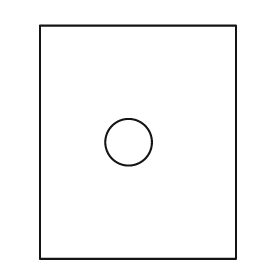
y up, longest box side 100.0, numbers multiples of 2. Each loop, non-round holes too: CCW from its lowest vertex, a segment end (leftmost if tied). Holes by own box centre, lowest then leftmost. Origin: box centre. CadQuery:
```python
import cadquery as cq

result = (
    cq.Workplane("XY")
    .moveTo(-42.0, -50.0)
    .lineTo(42.0, -50.0)
    .lineTo(42.0, 50.0)
    .lineTo(-42.0, 50.0)
    .close()
    .moveTo(-4.0, 0.0)
    .circle(10.0)
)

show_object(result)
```